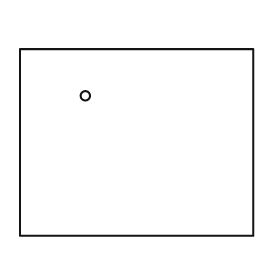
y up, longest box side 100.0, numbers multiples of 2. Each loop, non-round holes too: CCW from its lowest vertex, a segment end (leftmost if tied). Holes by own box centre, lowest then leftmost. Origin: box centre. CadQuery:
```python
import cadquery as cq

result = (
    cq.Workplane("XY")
    .moveTo(-50.0, -40.0)
    .lineTo(50.0, -40.0)
    .lineTo(50.0, 40.0)
    .lineTo(-50.0, 40.0)
    .close()
    .moveTo(-22.0, 20.0)
    .circle(2.0)
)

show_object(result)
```